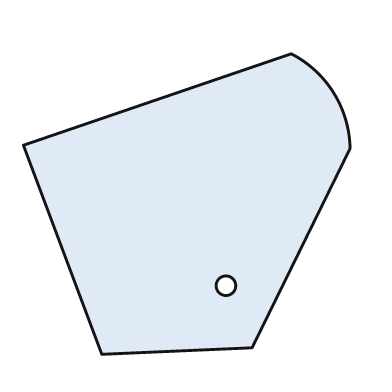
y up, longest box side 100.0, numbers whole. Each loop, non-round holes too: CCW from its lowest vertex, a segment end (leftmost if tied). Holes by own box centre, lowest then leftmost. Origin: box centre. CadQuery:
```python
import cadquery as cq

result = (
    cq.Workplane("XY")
    .moveTo(-26.0, -46.0)
    .lineTo(20.0, -44.0)
    .lineTo(50.0, 17.0)
    .threePointArc((45.0, 34.0), (32.0, 46.0))
    .lineTo(-50.0, 18.0)
    .close()
    .moveTo(12.0, -25.0)
    .circle(3.0)
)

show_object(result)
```